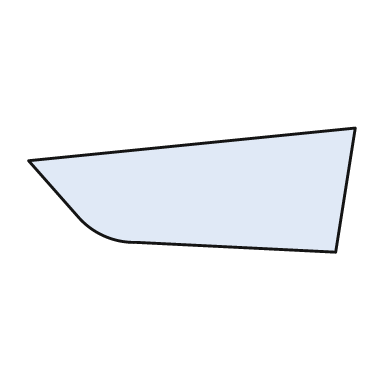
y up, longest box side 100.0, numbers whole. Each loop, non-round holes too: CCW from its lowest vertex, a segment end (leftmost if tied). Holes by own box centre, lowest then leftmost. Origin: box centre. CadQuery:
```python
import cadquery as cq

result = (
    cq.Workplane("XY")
    .moveTo(44.0, -19.0)
    .lineTo(50.0, 19.0)
    .lineTo(-50.0, 9.0)
    .lineTo(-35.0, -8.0)
    .threePointArc((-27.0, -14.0), (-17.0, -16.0))
    .close()
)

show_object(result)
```